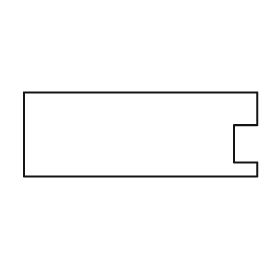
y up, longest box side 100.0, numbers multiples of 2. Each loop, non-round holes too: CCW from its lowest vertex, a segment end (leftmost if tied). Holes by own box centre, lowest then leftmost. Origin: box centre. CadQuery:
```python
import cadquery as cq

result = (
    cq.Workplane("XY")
    .moveTo(-50.0, -18.0)
    .lineTo(50.0, -18.0)
    .lineTo(50.0, -12.0)
    .lineTo(40.0, -12.0)
    .lineTo(40.0, 4.0)
    .lineTo(50.0, 4.0)
    .lineTo(50.0, 18.0)
    .lineTo(-50.0, 18.0)
    .close()
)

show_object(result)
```